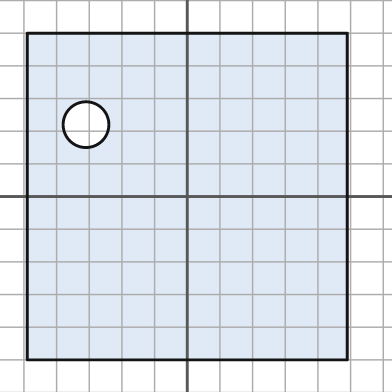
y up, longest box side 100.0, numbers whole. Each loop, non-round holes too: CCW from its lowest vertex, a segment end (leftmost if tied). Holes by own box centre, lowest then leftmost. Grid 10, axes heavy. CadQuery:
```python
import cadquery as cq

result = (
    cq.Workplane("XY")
    .moveTo(-49.0, -50.0)
    .lineTo(49.0, -50.0)
    .lineTo(49.0, 50.0)
    .lineTo(-49.0, 50.0)
    .close()
    .moveTo(-31.0, 22.0)
    .circle(7.0)
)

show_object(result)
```